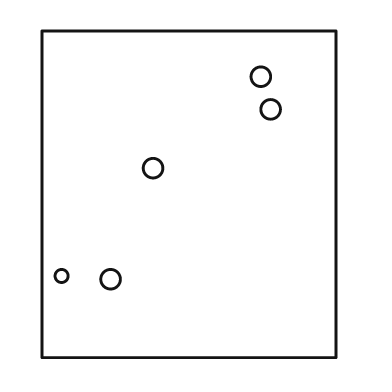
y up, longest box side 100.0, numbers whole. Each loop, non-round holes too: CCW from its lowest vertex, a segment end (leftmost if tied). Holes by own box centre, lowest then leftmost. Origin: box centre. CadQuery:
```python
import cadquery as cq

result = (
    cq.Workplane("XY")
    .moveTo(-45.0, -50.0)
    .lineTo(45.0, -50.0)
    .lineTo(45.0, 50.0)
    .lineTo(-45.0, 50.0)
    .close()
    .moveTo(-24.0, -26.0)
    .circle(3.0)
    .moveTo(-39.0, -25.0)
    .circle(2.0)
    .moveTo(-11.0, 8.0)
    .circle(3.0)
    .moveTo(25.0, 26.0)
    .circle(3.0)
    .moveTo(22.0, 36.0)
    .circle(3.0)
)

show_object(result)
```